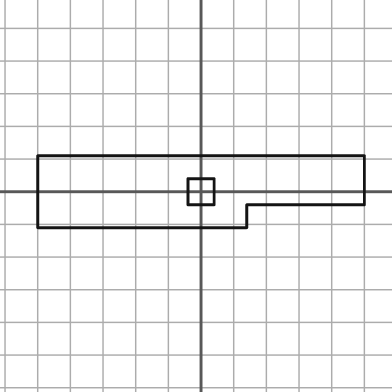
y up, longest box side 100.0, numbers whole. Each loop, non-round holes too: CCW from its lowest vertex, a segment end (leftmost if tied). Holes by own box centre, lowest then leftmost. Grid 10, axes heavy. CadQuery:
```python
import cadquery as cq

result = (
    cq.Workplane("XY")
    .moveTo(-50.0, -11.0)
    .lineTo(14.0, -11.0)
    .lineTo(14.0, -4.0)
    .lineTo(50.0, -4.0)
    .lineTo(50.0, 11.0)
    .lineTo(-50.0, 11.0)
    .close()
    .moveTo(-4.0, -4.0)
    .lineTo(4.0, -4.0)
    .lineTo(4.0, 4.0)
    .lineTo(-4.0, 4.0)
    .close()
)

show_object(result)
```